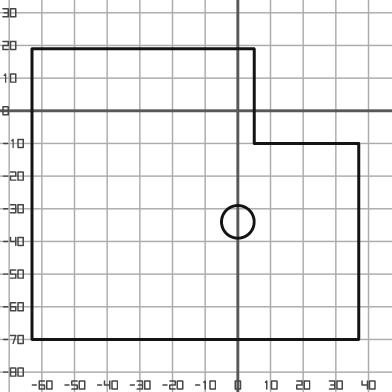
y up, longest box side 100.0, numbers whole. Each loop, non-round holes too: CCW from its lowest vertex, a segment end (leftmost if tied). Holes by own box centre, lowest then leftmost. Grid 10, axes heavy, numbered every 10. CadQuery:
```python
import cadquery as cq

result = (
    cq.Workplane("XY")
    .moveTo(-63.0, -70.0)
    .lineTo(37.0, -70.0)
    .lineTo(37.0, -10.0)
    .lineTo(5.0, -10.0)
    .lineTo(5.0, 19.0)
    .lineTo(-63.0, 19.0)
    .close()
    .moveTo(0.0, -34.0)
    .circle(5.0)
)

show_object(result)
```